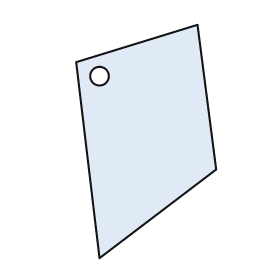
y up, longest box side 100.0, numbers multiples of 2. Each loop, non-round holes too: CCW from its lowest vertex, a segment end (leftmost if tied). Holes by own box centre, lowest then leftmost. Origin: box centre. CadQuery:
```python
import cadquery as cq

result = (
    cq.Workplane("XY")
    .moveTo(-20.0, -50.0)
    .lineTo(30.0, -12.0)
    .lineTo(22.0, 50.0)
    .lineTo(-30.0, 34.0)
    .close()
    .moveTo(-20.0, 28.0)
    .circle(4.0)
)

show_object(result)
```